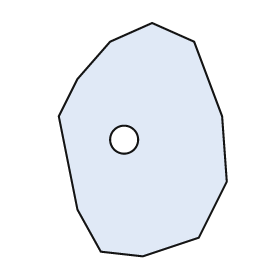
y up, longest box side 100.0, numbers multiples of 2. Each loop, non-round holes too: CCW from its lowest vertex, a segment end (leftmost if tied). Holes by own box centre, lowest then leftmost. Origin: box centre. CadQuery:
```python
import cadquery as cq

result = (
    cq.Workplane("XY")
    .moveTo(0.0, -50.0)
    .lineTo(24.0, -42.0)
    .lineTo(36.0, -18.0)
    .lineTo(34.0, 10.0)
    .lineTo(22.0, 42.0)
    .lineTo(4.0, 50.0)
    .lineTo(-14.0, 42.0)
    .lineTo(-28.0, 26.0)
    .lineTo(-36.0, 10.0)
    .lineTo(-28.0, -30.0)
    .lineTo(-18.0, -48.0)
    .close()
    .moveTo(-8.0, 0.0)
    .circle(6.0)
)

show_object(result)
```